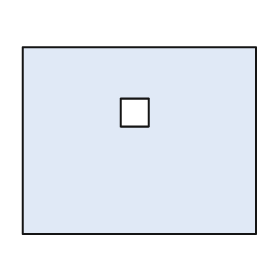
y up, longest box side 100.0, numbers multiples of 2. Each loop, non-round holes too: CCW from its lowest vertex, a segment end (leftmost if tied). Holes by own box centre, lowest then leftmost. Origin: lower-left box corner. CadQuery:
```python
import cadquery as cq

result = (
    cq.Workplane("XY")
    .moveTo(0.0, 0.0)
    .lineTo(100.0, 0.0)
    .lineTo(100.0, 80.0)
    .lineTo(0.0, 80.0)
    .close()
    .moveTo(42.0, 46.0)
    .lineTo(54.0, 46.0)
    .lineTo(54.0, 58.0)
    .lineTo(42.0, 58.0)
    .close()
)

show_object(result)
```